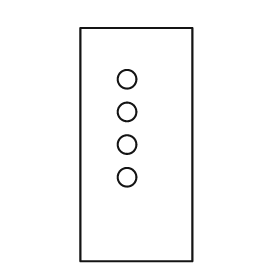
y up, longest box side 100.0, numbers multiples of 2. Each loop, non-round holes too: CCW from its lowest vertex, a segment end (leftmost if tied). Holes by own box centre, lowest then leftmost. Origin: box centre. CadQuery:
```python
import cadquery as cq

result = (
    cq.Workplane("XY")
    .moveTo(-24.0, -50.0)
    .lineTo(24.0, -50.0)
    .lineTo(24.0, 50.0)
    .lineTo(-24.0, 50.0)
    .close()
    .moveTo(-4.0, -14.0)
    .circle(4.0)
    .moveTo(-4.0, 0.0)
    .circle(4.0)
    .moveTo(-4.0, 14.0)
    .circle(4.0)
    .moveTo(-4.0, 28.0)
    .circle(4.0)
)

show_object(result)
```